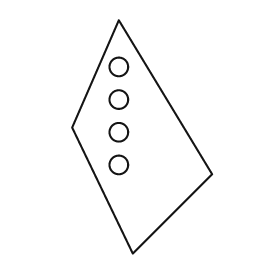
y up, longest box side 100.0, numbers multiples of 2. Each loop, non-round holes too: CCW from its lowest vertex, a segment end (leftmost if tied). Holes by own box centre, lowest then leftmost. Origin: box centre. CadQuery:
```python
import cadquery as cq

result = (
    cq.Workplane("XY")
    .moveTo(-4.0, -50.0)
    .lineTo(30.0, -16.0)
    .lineTo(-10.0, 50.0)
    .lineTo(-30.0, 4.0)
    .close()
    .moveTo(-10.0, -12.0)
    .circle(4.0)
    .moveTo(-10.0, 2.0)
    .circle(4.0)
    .moveTo(-10.0, 16.0)
    .circle(4.0)
    .moveTo(-10.0, 30.0)
    .circle(4.0)
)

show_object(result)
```